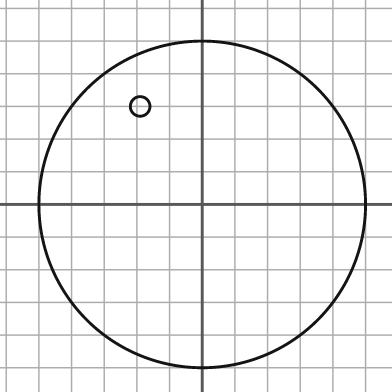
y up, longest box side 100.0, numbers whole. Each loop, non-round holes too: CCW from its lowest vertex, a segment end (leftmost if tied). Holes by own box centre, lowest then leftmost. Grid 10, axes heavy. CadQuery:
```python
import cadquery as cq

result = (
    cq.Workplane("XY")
    .moveTo(0.0, 0.0)
    .circle(50.0)
    .moveTo(-19.0, 30.0)
    .circle(3.0)
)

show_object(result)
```